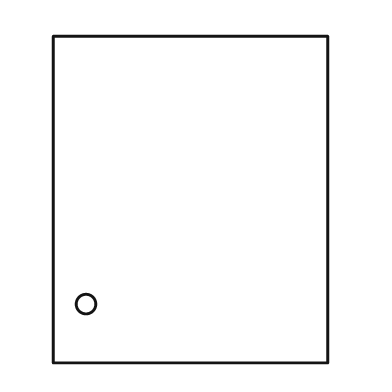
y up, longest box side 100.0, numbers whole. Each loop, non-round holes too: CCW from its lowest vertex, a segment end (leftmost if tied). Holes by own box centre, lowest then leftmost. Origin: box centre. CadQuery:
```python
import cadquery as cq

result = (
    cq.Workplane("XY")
    .moveTo(-42.0, -50.0)
    .lineTo(42.0, -50.0)
    .lineTo(42.0, 50.0)
    .lineTo(-42.0, 50.0)
    .close()
    .moveTo(-32.0, -32.0)
    .circle(3.0)
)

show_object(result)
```